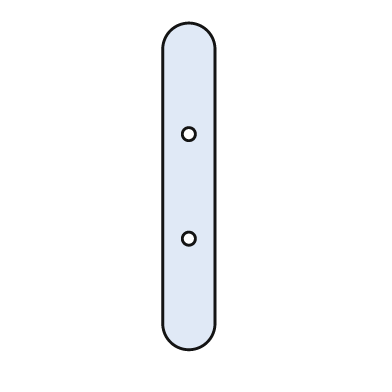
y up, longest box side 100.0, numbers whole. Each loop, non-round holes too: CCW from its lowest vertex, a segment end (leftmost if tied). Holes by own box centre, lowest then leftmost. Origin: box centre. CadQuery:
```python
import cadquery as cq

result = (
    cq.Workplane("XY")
    .moveTo(-8.0, -42.0)
    .threePointArc((0.0, -50.0), (8.0, -42.0))
    .lineTo(8.0, 42.0)
    .threePointArc((0.0, 50.0), (-8.0, 42.0))
    .close()
    .moveTo(0.0, -16.0)
    .circle(2.0)
    .moveTo(0.0, 16.0)
    .circle(2.0)
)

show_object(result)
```